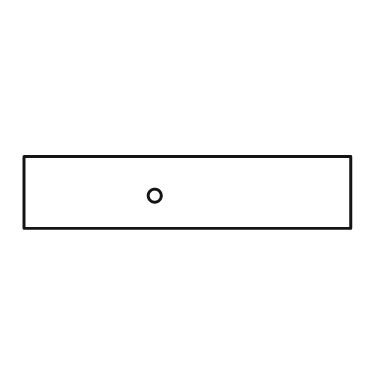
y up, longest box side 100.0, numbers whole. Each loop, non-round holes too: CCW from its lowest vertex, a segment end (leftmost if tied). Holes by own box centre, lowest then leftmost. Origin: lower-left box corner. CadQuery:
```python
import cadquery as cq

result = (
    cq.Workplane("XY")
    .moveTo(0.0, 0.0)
    .lineTo(100.0, 0.0)
    .lineTo(100.0, 22.0)
    .lineTo(0.0, 22.0)
    .close()
    .moveTo(40.0, 10.0)
    .circle(2.0)
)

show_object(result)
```